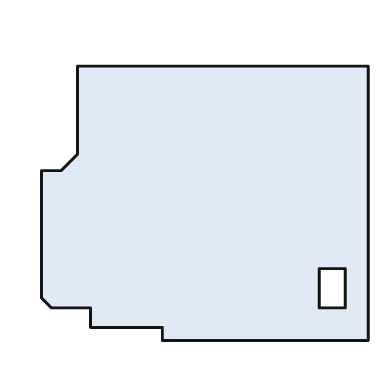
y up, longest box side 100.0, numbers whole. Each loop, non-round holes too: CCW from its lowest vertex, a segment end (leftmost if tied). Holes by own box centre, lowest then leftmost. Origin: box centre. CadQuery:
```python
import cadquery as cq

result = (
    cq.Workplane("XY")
    .moveTo(-13.0, -42.0)
    .lineTo(50.0, -42.0)
    .lineTo(50.0, 42.0)
    .lineTo(-39.0, 42.0)
    .lineTo(-39.0, 15.0)
    .lineTo(-44.0, 10.0)
    .lineTo(-50.0, 10.0)
    .lineTo(-50.0, -29.0)
    .lineTo(-47.0, -32.0)
    .lineTo(-35.0, -32.0)
    .lineTo(-35.0, -38.0)
    .lineTo(-13.0, -38.0)
    .close()
    .moveTo(35.0, -32.0)
    .lineTo(43.0, -32.0)
    .lineTo(43.0, -20.0)
    .lineTo(35.0, -20.0)
    .close()
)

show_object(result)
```